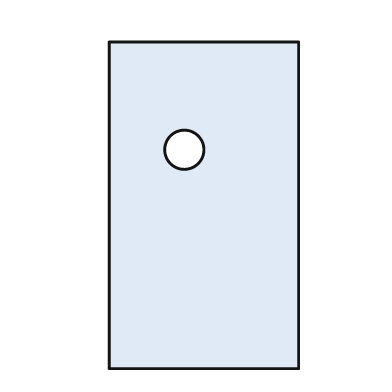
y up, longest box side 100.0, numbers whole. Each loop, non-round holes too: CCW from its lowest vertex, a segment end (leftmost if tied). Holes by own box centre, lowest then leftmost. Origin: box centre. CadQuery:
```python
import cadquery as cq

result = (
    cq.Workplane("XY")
    .moveTo(-29.0, -50.0)
    .lineTo(29.0, -50.0)
    .lineTo(29.0, 50.0)
    .lineTo(-29.0, 50.0)
    .close()
    .moveTo(-6.0, 17.0)
    .circle(6.0)
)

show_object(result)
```